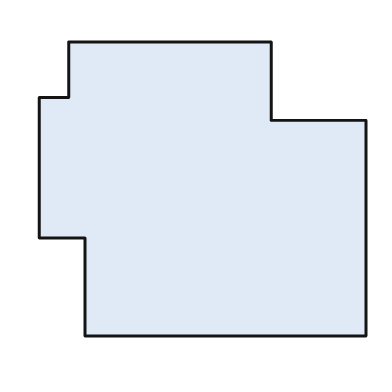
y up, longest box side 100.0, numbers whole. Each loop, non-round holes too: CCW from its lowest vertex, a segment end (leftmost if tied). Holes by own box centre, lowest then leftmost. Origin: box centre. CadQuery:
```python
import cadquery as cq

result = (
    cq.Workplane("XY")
    .moveTo(-36.0, -45.0)
    .lineTo(50.0, -45.0)
    .lineTo(50.0, 21.0)
    .lineTo(21.0, 21.0)
    .lineTo(21.0, 45.0)
    .lineTo(-41.0, 45.0)
    .lineTo(-41.0, 28.0)
    .lineTo(-50.0, 28.0)
    .lineTo(-50.0, -15.0)
    .lineTo(-36.0, -15.0)
    .close()
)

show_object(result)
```